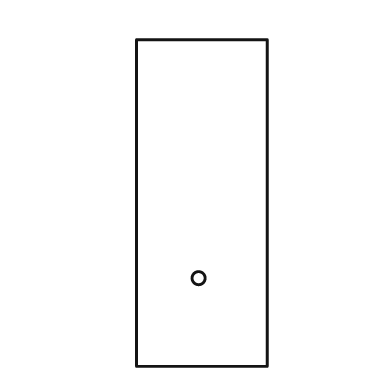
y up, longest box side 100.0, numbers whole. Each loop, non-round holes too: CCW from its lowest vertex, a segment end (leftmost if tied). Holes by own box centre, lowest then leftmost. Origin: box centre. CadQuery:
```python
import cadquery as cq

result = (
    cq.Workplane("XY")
    .moveTo(-20.0, -50.0)
    .lineTo(20.0, -50.0)
    .lineTo(20.0, 50.0)
    .lineTo(-20.0, 50.0)
    .close()
    .moveTo(-1.0, -23.0)
    .circle(2.0)
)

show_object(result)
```